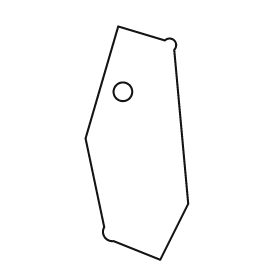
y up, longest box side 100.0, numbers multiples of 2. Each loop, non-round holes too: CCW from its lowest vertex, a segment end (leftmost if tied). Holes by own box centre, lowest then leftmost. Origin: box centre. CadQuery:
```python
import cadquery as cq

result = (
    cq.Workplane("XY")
    .moveTo(10.0, -50.0)
    .lineTo(22.0, -26.0)
    .lineTo(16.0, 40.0)
    .threePointArc((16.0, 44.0), (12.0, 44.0))
    .lineTo(-8.0, 50.0)
    .lineTo(-22.0, 2.0)
    .lineTo(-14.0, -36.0)
    .threePointArc((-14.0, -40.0), (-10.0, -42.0))
    .close()
    .moveTo(-6.0, 22.0)
    .circle(4.0)
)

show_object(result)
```